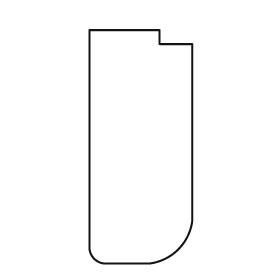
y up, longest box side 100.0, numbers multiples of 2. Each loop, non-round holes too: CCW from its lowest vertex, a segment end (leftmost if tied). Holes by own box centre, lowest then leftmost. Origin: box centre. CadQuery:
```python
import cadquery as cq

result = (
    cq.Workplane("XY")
    .moveTo(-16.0, -50.0)
    .lineTo(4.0, -50.0)
    .threePointArc((16.0, -44.0), (22.0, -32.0))
    .lineTo(22.0, 44.0)
    .lineTo(8.0, 44.0)
    .lineTo(8.0, 50.0)
    .lineTo(-22.0, 50.0)
    .lineTo(-22.0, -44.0)
    .threePointArc((-20.0, -48.0), (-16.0, -50.0))
    .close()
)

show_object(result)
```